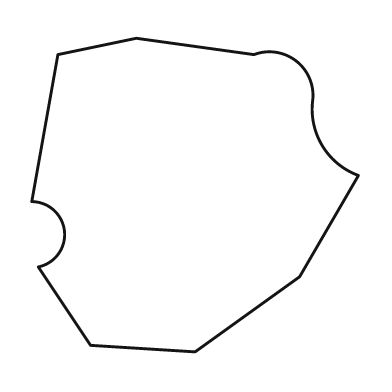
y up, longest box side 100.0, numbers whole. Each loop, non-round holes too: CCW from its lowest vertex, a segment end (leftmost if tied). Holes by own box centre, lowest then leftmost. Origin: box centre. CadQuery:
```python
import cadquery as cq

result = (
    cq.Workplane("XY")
    .moveTo(0.0, -48.0)
    .lineTo(32.0, -25.0)
    .lineTo(50.0, 6.0)
    .threePointArc((39.0, 15.0), (36.0, 29.0))
    .threePointArc((31.0, 41.0), (18.0, 43.0))
    .lineTo(-18.0, 48.0)
    .lineTo(-42.0, 43.0)
    .lineTo(-50.0, -2.0)
    .threePointArc((-40.0, -11.0), (-48.0, -22.0))
    .lineTo(-32.0, -46.0)
    .close()
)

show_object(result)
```